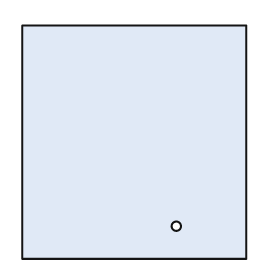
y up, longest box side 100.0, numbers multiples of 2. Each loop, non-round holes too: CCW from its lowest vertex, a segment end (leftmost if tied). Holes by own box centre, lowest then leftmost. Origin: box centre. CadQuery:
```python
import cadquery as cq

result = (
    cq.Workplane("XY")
    .moveTo(-48.0, -50.0)
    .lineTo(48.0, -50.0)
    .lineTo(48.0, 50.0)
    .lineTo(-48.0, 50.0)
    .close()
    .moveTo(18.0, -36.0)
    .circle(2.0)
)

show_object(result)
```